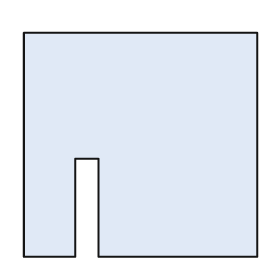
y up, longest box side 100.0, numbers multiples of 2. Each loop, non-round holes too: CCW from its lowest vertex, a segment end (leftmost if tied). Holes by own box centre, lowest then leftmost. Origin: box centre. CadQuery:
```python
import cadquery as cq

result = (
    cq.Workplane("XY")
    .moveTo(-50.0, -48.0)
    .lineTo(-28.0, -48.0)
    .lineTo(-28.0, -6.0)
    .lineTo(-18.0, -6.0)
    .lineTo(-18.0, -48.0)
    .lineTo(50.0, -48.0)
    .lineTo(50.0, 48.0)
    .lineTo(-50.0, 48.0)
    .close()
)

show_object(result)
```